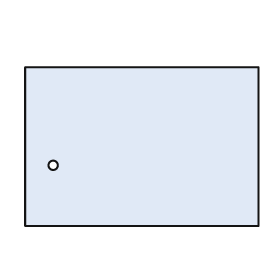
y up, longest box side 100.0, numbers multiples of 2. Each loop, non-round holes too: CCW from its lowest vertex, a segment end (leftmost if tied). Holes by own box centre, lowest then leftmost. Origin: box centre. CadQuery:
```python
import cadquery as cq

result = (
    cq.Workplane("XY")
    .moveTo(-50.0, -34.0)
    .lineTo(50.0, -34.0)
    .lineTo(50.0, 34.0)
    .lineTo(-50.0, 34.0)
    .close()
    .moveTo(-38.0, -8.0)
    .circle(2.0)
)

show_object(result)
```